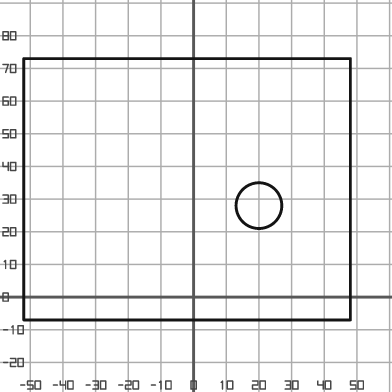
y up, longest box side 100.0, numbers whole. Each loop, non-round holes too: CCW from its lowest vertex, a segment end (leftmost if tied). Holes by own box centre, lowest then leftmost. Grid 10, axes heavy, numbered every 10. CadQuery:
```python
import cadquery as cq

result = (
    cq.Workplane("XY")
    .moveTo(-52.0, -7.0)
    .lineTo(48.0, -7.0)
    .lineTo(48.0, 73.0)
    .lineTo(-52.0, 73.0)
    .close()
    .moveTo(20.0, 28.0)
    .circle(7.0)
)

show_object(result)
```